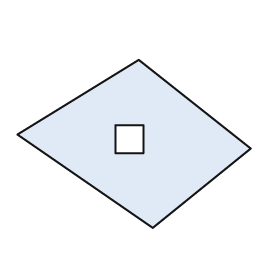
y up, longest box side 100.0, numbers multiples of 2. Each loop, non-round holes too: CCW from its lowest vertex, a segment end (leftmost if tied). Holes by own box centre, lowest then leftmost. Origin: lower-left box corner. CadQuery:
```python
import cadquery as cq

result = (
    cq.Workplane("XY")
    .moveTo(58.0, 0.0)
    .lineTo(100.0, 34.0)
    .lineTo(52.0, 72.0)
    .lineTo(0.0, 40.0)
    .close()
    .moveTo(42.0, 32.0)
    .lineTo(54.0, 32.0)
    .lineTo(54.0, 44.0)
    .lineTo(42.0, 44.0)
    .close()
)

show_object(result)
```